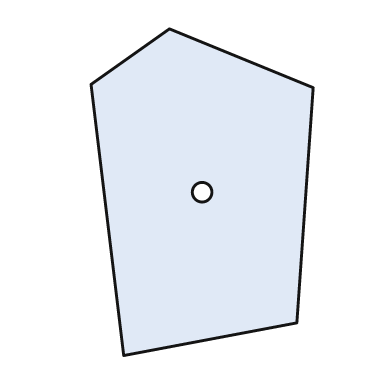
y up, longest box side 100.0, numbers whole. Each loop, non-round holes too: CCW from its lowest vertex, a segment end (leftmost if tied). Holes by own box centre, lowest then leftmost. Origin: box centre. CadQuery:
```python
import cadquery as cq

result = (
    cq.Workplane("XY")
    .moveTo(-24.0, -50.0)
    .lineTo(29.0, -40.0)
    .lineTo(34.0, 32.0)
    .lineTo(-10.0, 50.0)
    .lineTo(-34.0, 33.0)
    .close()
    .moveTo(0.0, 0.0)
    .circle(3.0)
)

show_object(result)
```